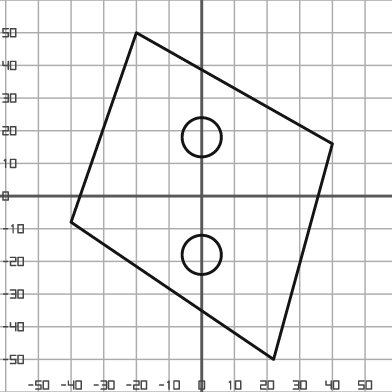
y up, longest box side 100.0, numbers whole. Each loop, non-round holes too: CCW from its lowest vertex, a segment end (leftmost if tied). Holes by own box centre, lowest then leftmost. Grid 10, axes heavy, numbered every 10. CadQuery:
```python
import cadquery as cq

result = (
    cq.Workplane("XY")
    .moveTo(22.0, -50.0)
    .lineTo(40.0, 16.0)
    .lineTo(-20.0, 50.0)
    .lineTo(-40.0, -8.0)
    .close()
    .moveTo(0.0, -18.0)
    .circle(6.0)
    .moveTo(0.0, 18.0)
    .circle(6.0)
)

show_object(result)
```